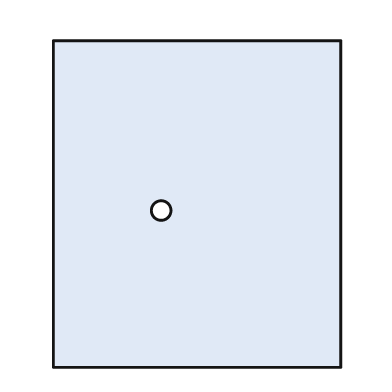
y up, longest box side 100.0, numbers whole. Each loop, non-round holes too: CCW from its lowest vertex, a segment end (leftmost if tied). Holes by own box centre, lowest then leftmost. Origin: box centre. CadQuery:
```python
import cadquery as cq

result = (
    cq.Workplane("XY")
    .moveTo(-44.0, -50.0)
    .lineTo(44.0, -50.0)
    .lineTo(44.0, 50.0)
    .lineTo(-44.0, 50.0)
    .close()
    .moveTo(-11.0, -2.0)
    .circle(3.0)
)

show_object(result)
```